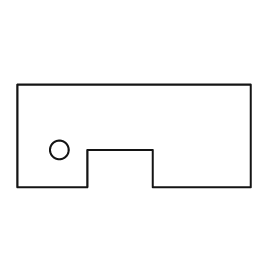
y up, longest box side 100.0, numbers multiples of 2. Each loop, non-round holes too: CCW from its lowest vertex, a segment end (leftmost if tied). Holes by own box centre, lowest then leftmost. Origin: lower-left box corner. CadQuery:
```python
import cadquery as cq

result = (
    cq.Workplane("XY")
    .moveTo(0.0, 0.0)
    .lineTo(30.0, 0.0)
    .lineTo(30.0, 16.0)
    .lineTo(58.0, 16.0)
    .lineTo(58.0, 0.0)
    .lineTo(100.0, 0.0)
    .lineTo(100.0, 44.0)
    .lineTo(0.0, 44.0)
    .close()
    .moveTo(18.0, 16.0)
    .circle(4.0)
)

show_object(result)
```